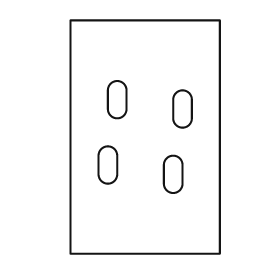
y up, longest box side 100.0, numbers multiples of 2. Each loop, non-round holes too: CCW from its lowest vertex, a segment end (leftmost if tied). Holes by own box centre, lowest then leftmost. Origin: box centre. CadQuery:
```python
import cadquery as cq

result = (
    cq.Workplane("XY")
    .moveTo(-32.0, -50.0)
    .lineTo(32.0, -50.0)
    .lineTo(32.0, 50.0)
    .lineTo(-32.0, 50.0)
    .close()
    .moveTo(8.0, -20.0)
    .threePointArc((12.0, -24.0), (16.0, -20.0))
    .lineTo(16.0, -12.0)
    .threePointArc((12.0, -8.0), (8.0, -12.0))
    .close()
    .moveTo(-20.0, -16.0)
    .threePointArc((-16.0, -20.0), (-12.0, -16.0))
    .lineTo(-12.0, -8.0)
    .threePointArc((-16.0, -4.0), (-20.0, -8.0))
    .close()
    .moveTo(12.0, 8.0)
    .threePointArc((16.0, 4.0), (20.0, 8.0))
    .lineTo(20.0, 16.0)
    .threePointArc((16.0, 20.0), (12.0, 16.0))
    .close()
    .moveTo(-16.0, 12.0)
    .threePointArc((-12.0, 8.0), (-8.0, 12.0))
    .lineTo(-8.0, 20.0)
    .threePointArc((-12.0, 24.0), (-16.0, 20.0))
    .close()
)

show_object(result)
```